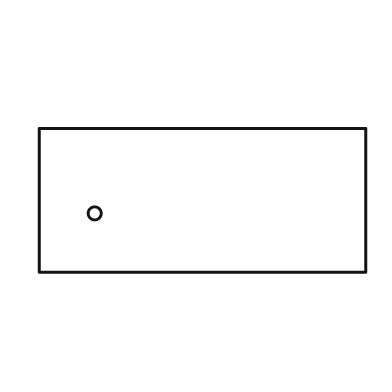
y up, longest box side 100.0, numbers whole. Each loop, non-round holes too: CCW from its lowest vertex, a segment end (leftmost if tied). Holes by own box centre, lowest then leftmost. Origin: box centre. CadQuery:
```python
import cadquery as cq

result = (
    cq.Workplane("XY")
    .moveTo(-50.0, -22.0)
    .lineTo(50.0, -22.0)
    .lineTo(50.0, 22.0)
    .lineTo(-50.0, 22.0)
    .close()
    .moveTo(-33.0, -4.0)
    .circle(2.0)
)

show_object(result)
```